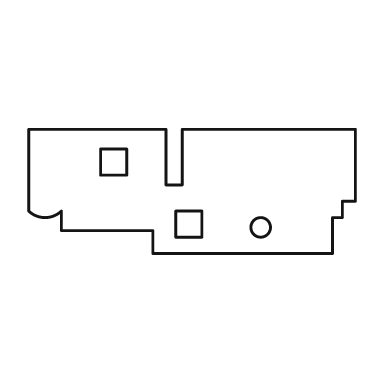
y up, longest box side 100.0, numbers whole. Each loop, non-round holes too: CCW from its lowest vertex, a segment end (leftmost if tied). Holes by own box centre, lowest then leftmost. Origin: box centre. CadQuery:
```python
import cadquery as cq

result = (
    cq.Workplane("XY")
    .moveTo(-12.0, -19.0)
    .lineTo(43.0, -19.0)
    .lineTo(43.0, -8.0)
    .lineTo(46.0, -8.0)
    .lineTo(46.0, -3.0)
    .lineTo(50.0, -3.0)
    .lineTo(50.0, 19.0)
    .lineTo(-3.0, 19.0)
    .lineTo(-3.0, 2.0)
    .lineTo(-8.0, 2.0)
    .lineTo(-8.0, 19.0)
    .lineTo(-50.0, 19.0)
    .lineTo(-50.0, -6.0)
    .threePointArc((-45.0, -8.0), (-40.0, -6.0))
    .lineTo(-40.0, -12.0)
    .lineTo(-12.0, -12.0)
    .close()
    .moveTo(21.0, -11.0)
    .circle(3.0)
    .moveTo(-5.0, -14.0)
    .lineTo(3.0, -14.0)
    .lineTo(3.0, -6.0)
    .lineTo(-5.0, -6.0)
    .close()
    .moveTo(-28.0, 5.0)
    .lineTo(-20.0, 5.0)
    .lineTo(-20.0, 13.0)
    .lineTo(-28.0, 13.0)
    .close()
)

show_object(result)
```